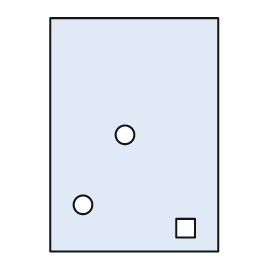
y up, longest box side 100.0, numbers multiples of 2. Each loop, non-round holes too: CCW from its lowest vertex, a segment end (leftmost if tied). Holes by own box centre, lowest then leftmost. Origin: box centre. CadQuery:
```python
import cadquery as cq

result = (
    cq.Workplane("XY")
    .moveTo(-36.0, -50.0)
    .lineTo(36.0, -50.0)
    .lineTo(36.0, 50.0)
    .lineTo(-36.0, 50.0)
    .close()
    .moveTo(18.0, -44.0)
    .lineTo(26.0, -44.0)
    .lineTo(26.0, -36.0)
    .lineTo(18.0, -36.0)
    .close()
    .moveTo(-22.0, -30.0)
    .circle(4.0)
    .moveTo(-4.0, 0.0)
    .circle(4.0)
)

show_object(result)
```